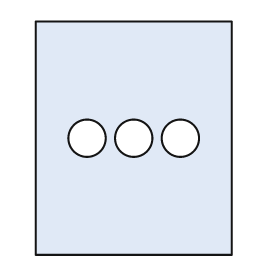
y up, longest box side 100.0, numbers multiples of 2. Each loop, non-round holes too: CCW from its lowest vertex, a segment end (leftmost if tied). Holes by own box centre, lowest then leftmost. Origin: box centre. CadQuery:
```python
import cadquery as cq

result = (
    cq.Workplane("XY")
    .moveTo(-42.0, -50.0)
    .lineTo(42.0, -50.0)
    .lineTo(42.0, 50.0)
    .lineTo(-42.0, 50.0)
    .close()
    .moveTo(-20.0, 0.0)
    .circle(8.0)
    .moveTo(0.0, 0.0)
    .circle(8.0)
    .moveTo(20.0, 0.0)
    .circle(8.0)
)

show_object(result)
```